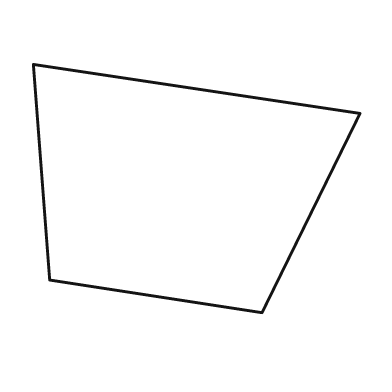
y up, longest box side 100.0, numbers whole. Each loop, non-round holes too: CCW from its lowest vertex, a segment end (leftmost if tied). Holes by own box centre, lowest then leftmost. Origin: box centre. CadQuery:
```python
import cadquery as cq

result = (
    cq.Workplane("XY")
    .moveTo(20.0, -38.0)
    .lineTo(50.0, 23.0)
    .lineTo(-50.0, 38.0)
    .lineTo(-45.0, -28.0)
    .close()
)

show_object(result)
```